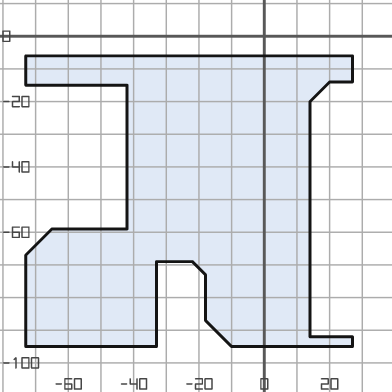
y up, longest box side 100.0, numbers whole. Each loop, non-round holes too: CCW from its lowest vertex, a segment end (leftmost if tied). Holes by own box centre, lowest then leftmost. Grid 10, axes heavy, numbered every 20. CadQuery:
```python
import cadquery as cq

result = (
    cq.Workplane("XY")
    .moveTo(-73.0, -95.0)
    .lineTo(-33.0, -95.0)
    .lineTo(-33.0, -69.0)
    .lineTo(-22.0, -69.0)
    .lineTo(-18.0, -73.0)
    .lineTo(-18.0, -87.0)
    .lineTo(-10.0, -95.0)
    .lineTo(27.0, -95.0)
    .lineTo(27.0, -92.0)
    .lineTo(14.0, -92.0)
    .lineTo(14.0, -20.0)
    .lineTo(20.0, -14.0)
    .lineTo(27.0, -14.0)
    .lineTo(27.0, -6.0)
    .lineTo(-73.0, -6.0)
    .lineTo(-73.0, -15.0)
    .lineTo(-42.0, -15.0)
    .lineTo(-42.0, -59.0)
    .lineTo(-65.0, -59.0)
    .lineTo(-73.0, -67.0)
    .close()
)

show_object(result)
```